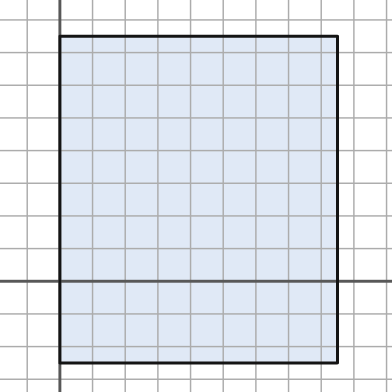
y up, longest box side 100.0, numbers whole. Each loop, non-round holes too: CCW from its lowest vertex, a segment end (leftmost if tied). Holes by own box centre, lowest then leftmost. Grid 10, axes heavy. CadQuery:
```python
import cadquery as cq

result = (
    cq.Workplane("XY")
    .moveTo(0.0, -25.0)
    .lineTo(85.0, -25.0)
    .lineTo(85.0, 75.0)
    .lineTo(0.0, 75.0)
    .close()
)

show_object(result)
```